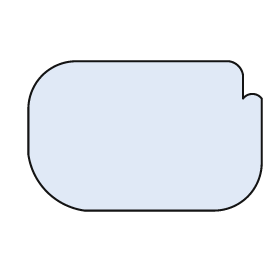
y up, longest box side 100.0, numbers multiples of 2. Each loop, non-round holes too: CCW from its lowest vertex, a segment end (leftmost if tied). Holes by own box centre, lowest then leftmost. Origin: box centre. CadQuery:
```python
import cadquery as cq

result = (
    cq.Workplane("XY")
    .moveTo(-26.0, -32.0)
    .lineTo(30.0, -32.0)
    .threePointArc((44.0, -26.0), (50.0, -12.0))
    .lineTo(50.0, 16.0)
    .threePointArc((46.0, 18.0), (42.0, 16.0))
    .lineTo(42.0, 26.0)
    .threePointArc((40.0, 30.0), (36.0, 32.0))
    .lineTo(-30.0, 32.0)
    .threePointArc((-44.0, 26.0), (-50.0, 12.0))
    .lineTo(-50.0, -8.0)
    .threePointArc((-42.0, -24.0), (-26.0, -32.0))
    .close()
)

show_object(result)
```